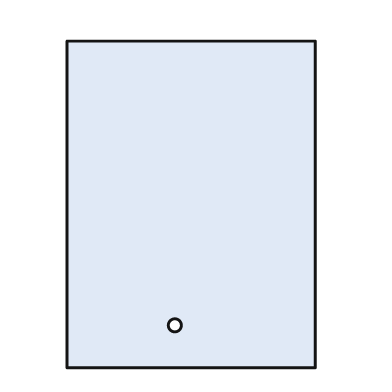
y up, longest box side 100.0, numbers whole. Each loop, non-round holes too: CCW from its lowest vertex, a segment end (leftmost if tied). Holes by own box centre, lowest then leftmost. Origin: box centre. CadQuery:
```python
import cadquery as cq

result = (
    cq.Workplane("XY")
    .moveTo(-38.0, -50.0)
    .lineTo(38.0, -50.0)
    .lineTo(38.0, 50.0)
    .lineTo(-38.0, 50.0)
    .close()
    .moveTo(-5.0, -37.0)
    .circle(2.0)
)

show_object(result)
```